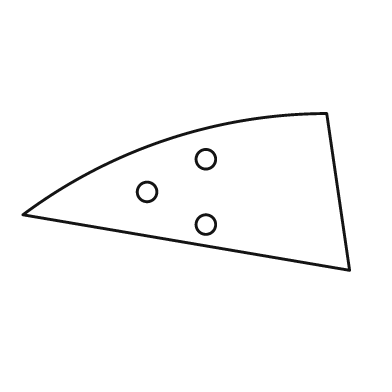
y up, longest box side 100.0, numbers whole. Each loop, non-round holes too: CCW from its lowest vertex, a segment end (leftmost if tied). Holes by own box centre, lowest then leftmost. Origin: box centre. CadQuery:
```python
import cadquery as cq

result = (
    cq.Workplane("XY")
    .moveTo(50.0, -24.0)
    .lineTo(43.0, 24.0)
    .threePointArc((-6.0, 16.0), (-50.0, -7.0))
    .close()
    .moveTo(6.0, -10.0)
    .circle(3.0)
    .moveTo(-12.0, 0.0)
    .circle(3.0)
    .moveTo(6.0, 10.0)
    .circle(3.0)
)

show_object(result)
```